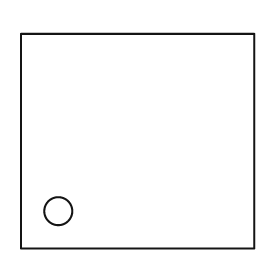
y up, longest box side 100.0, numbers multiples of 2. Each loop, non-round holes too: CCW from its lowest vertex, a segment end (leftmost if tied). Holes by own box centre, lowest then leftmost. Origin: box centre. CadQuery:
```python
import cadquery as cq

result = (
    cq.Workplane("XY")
    .moveTo(-50.0, -46.0)
    .lineTo(50.0, -46.0)
    .lineTo(50.0, 46.0)
    .lineTo(-50.0, 46.0)
    .close()
    .moveTo(-34.0, -30.0)
    .circle(6.0)
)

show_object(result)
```